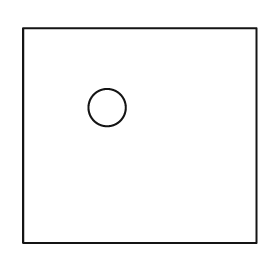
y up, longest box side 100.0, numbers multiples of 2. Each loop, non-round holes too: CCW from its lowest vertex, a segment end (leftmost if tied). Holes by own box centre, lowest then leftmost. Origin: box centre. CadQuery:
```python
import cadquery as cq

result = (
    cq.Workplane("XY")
    .moveTo(-50.0, -46.0)
    .lineTo(50.0, -46.0)
    .lineTo(50.0, 46.0)
    .lineTo(-50.0, 46.0)
    .close()
    .moveTo(-14.0, 12.0)
    .circle(8.0)
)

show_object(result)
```